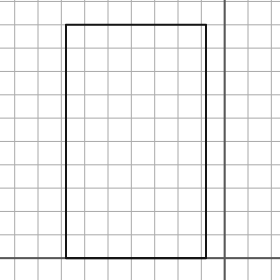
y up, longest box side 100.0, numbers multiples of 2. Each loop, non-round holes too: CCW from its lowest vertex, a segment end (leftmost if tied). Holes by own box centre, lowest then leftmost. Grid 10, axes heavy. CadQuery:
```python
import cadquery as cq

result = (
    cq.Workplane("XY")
    .moveTo(-68.0, 0.0)
    .lineTo(-8.0, 0.0)
    .lineTo(-8.0, 100.0)
    .lineTo(-68.0, 100.0)
    .close()
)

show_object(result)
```